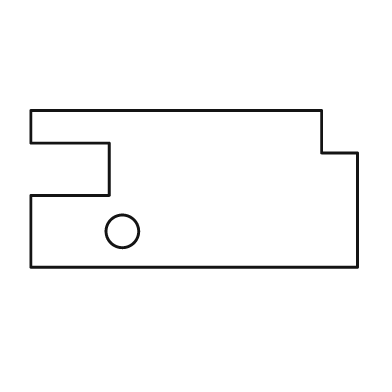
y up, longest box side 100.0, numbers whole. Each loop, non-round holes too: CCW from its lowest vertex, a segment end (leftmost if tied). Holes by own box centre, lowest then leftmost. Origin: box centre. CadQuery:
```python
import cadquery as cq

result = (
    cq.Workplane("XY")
    .moveTo(-50.0, -24.0)
    .lineTo(50.0, -24.0)
    .lineTo(50.0, 11.0)
    .lineTo(39.0, 11.0)
    .lineTo(39.0, 24.0)
    .lineTo(-50.0, 24.0)
    .lineTo(-50.0, 14.0)
    .lineTo(-26.0, 14.0)
    .lineTo(-26.0, -2.0)
    .lineTo(-50.0, -2.0)
    .close()
    .moveTo(-22.0, -13.0)
    .circle(5.0)
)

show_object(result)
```